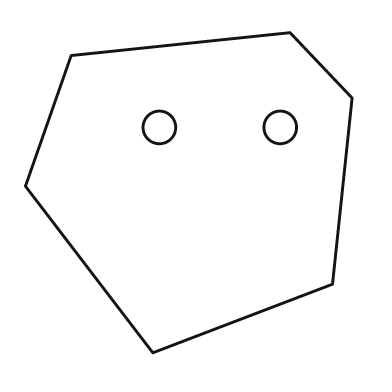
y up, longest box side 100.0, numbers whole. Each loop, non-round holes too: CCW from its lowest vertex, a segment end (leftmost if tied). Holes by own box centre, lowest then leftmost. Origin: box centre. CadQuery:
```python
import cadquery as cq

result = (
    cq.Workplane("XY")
    .moveTo(-11.0, -49.0)
    .lineTo(44.0, -28.0)
    .lineTo(50.0, 29.0)
    .lineTo(31.0, 49.0)
    .lineTo(-36.0, 42.0)
    .lineTo(-50.0, 2.0)
    .close()
    .moveTo(-9.0, 20.0)
    .circle(5.0)
    .moveTo(28.0, 20.0)
    .circle(5.0)
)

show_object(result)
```